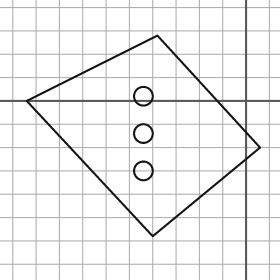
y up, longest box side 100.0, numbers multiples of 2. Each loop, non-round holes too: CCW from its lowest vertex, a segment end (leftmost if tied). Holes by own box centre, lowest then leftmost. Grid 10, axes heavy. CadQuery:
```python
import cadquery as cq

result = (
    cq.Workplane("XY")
    .moveTo(-40.0, -58.0)
    .lineTo(6.0, -20.0)
    .lineTo(-38.0, 28.0)
    .lineTo(-94.0, 0.0)
    .close()
    .moveTo(-44.0, -30.0)
    .circle(4.0)
    .moveTo(-44.0, -14.0)
    .circle(4.0)
    .moveTo(-44.0, 2.0)
    .circle(4.0)
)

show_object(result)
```